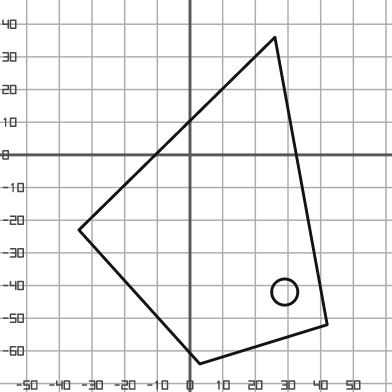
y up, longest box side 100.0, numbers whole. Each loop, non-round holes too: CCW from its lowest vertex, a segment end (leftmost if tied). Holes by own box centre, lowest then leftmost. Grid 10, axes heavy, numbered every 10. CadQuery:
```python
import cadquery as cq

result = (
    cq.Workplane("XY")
    .moveTo(3.0, -64.0)
    .lineTo(42.0, -52.0)
    .lineTo(26.0, 36.0)
    .lineTo(-34.0, -23.0)
    .close()
    .moveTo(29.0, -42.0)
    .circle(4.0)
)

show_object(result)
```